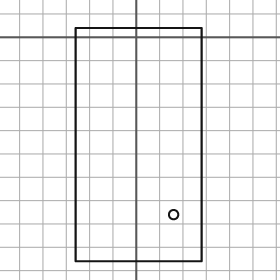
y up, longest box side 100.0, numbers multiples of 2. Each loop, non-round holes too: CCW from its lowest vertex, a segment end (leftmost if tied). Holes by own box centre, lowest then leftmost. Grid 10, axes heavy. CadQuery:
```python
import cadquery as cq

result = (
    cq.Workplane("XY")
    .moveTo(-26.0, -96.0)
    .lineTo(28.0, -96.0)
    .lineTo(28.0, 4.0)
    .lineTo(-26.0, 4.0)
    .close()
    .moveTo(16.0, -76.0)
    .circle(2.0)
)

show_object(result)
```